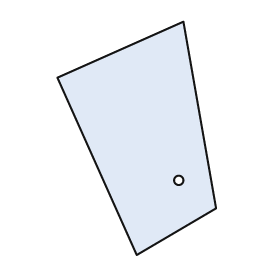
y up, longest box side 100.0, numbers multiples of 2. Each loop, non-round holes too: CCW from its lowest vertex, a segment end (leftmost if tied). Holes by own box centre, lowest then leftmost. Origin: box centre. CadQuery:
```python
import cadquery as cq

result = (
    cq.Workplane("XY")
    .moveTo(0.0, -50.0)
    .lineTo(34.0, -30.0)
    .lineTo(20.0, 50.0)
    .lineTo(-34.0, 26.0)
    .close()
    .moveTo(18.0, -18.0)
    .circle(2.0)
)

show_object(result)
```